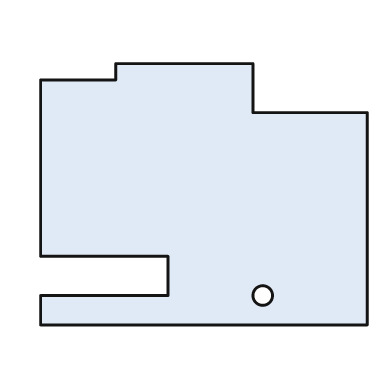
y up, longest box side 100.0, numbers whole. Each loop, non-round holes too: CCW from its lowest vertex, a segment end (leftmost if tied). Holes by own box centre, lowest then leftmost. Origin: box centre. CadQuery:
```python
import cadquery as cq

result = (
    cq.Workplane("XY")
    .moveTo(-50.0, -40.0)
    .lineTo(50.0, -40.0)
    .lineTo(50.0, 25.0)
    .lineTo(15.0, 25.0)
    .lineTo(15.0, 40.0)
    .lineTo(-27.0, 40.0)
    .lineTo(-27.0, 35.0)
    .lineTo(-50.0, 35.0)
    .lineTo(-50.0, -19.0)
    .lineTo(-11.0, -19.0)
    .lineTo(-11.0, -31.0)
    .lineTo(-50.0, -31.0)
    .close()
    .moveTo(18.0, -31.0)
    .circle(3.0)
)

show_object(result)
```